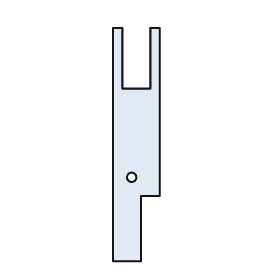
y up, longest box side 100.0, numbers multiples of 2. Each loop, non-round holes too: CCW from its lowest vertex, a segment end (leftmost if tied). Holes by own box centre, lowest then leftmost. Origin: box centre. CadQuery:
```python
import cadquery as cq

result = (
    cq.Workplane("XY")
    .moveTo(-10.0, -50.0)
    .lineTo(2.0, -50.0)
    .lineTo(2.0, -22.0)
    .lineTo(10.0, -22.0)
    .lineTo(10.0, 50.0)
    .lineTo(6.0, 50.0)
    .lineTo(6.0, 24.0)
    .lineTo(-6.0, 24.0)
    .lineTo(-6.0, 50.0)
    .lineTo(-10.0, 50.0)
    .close()
    .moveTo(-2.0, -14.0)
    .circle(2.0)
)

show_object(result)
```